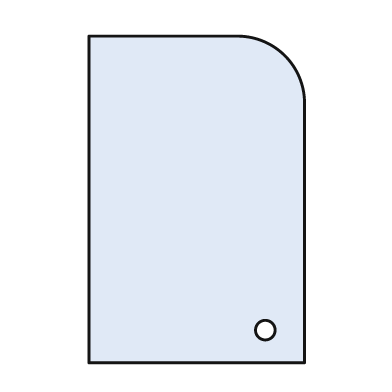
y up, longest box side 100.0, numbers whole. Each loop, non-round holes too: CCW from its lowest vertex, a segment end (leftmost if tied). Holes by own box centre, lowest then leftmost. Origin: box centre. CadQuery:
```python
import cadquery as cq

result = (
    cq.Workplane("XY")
    .moveTo(-33.0, -50.0)
    .lineTo(33.0, -50.0)
    .lineTo(33.0, 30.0)
    .threePointArc((27.0, 44.0), (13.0, 50.0))
    .lineTo(-33.0, 50.0)
    .close()
    .moveTo(21.0, -40.0)
    .circle(3.0)
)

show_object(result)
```